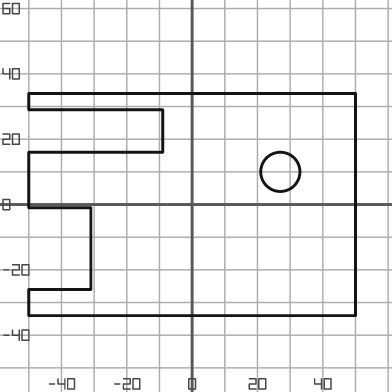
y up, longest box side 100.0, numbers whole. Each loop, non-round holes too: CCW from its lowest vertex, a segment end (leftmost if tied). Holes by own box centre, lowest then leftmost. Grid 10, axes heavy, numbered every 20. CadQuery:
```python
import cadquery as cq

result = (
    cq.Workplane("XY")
    .moveTo(-50.0, -34.0)
    .lineTo(50.0, -34.0)
    .lineTo(50.0, 34.0)
    .lineTo(-50.0, 34.0)
    .lineTo(-50.0, 29.0)
    .lineTo(-9.0, 29.0)
    .lineTo(-9.0, 16.0)
    .lineTo(-50.0, 16.0)
    .lineTo(-50.0, -1.0)
    .lineTo(-31.0, -1.0)
    .lineTo(-31.0, -26.0)
    .lineTo(-50.0, -26.0)
    .close()
    .moveTo(27.0, 10.0)
    .circle(6.0)
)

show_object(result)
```